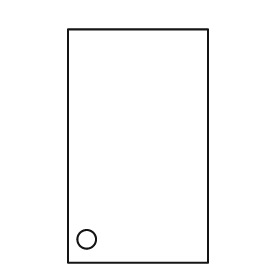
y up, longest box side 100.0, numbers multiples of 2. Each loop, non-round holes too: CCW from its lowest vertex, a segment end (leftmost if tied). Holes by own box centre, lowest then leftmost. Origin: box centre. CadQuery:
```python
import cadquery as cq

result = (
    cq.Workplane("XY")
    .moveTo(-30.0, -50.0)
    .lineTo(30.0, -50.0)
    .lineTo(30.0, 50.0)
    .lineTo(-30.0, 50.0)
    .close()
    .moveTo(-22.0, -40.0)
    .circle(4.0)
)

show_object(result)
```